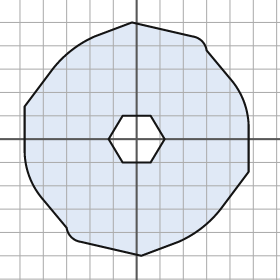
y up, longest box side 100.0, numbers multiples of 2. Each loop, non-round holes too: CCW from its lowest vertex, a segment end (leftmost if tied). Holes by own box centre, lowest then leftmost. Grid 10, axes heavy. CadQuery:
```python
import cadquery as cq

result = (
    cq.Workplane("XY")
    .moveTo(2.0, -50.0)
    .lineTo(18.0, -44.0)
    .threePointArc((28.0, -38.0), (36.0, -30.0))
    .lineTo(48.0, -14.0)
    .lineTo(48.0, 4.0)
    .threePointArc((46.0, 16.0), (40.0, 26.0))
    .lineTo(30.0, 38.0)
    .threePointArc((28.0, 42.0), (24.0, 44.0))
    .lineTo(-2.0, 50.0)
    .lineTo(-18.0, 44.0)
    .threePointArc((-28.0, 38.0), (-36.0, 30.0))
    .lineTo(-48.0, 14.0)
    .lineTo(-48.0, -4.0)
    .threePointArc((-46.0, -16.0), (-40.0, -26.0))
    .lineTo(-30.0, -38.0)
    .threePointArc((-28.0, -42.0), (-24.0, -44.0))
    .close()
    .moveTo(-6.0, -10.0)
    .lineTo(6.0, -10.0)
    .lineTo(12.0, 0.0)
    .lineTo(6.0, 10.0)
    .lineTo(-6.0, 10.0)
    .lineTo(-12.0, 0.0)
    .close()
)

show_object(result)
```